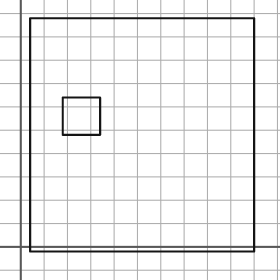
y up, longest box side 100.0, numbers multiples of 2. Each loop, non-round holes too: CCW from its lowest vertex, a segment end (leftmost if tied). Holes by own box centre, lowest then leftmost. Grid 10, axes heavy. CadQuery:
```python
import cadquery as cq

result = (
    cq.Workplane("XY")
    .moveTo(4.0, -2.0)
    .lineTo(100.0, -2.0)
    .lineTo(100.0, 98.0)
    .lineTo(4.0, 98.0)
    .close()
    .moveTo(18.0, 48.0)
    .lineTo(34.0, 48.0)
    .lineTo(34.0, 64.0)
    .lineTo(18.0, 64.0)
    .close()
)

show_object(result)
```